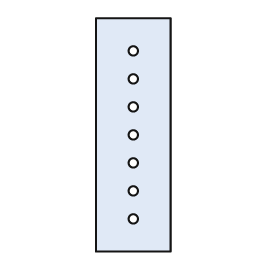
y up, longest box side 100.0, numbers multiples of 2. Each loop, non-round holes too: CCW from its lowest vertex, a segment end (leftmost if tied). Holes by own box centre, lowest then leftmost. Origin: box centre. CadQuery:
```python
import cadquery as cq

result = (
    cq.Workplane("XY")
    .moveTo(-16.0, -50.0)
    .lineTo(16.0, -50.0)
    .lineTo(16.0, 50.0)
    .lineTo(-16.0, 50.0)
    .close()
    .moveTo(0.0, -36.0)
    .circle(2.0)
    .moveTo(0.0, -24.0)
    .circle(2.0)
    .moveTo(0.0, -12.0)
    .circle(2.0)
    .moveTo(0.0, 0.0)
    .circle(2.0)
    .moveTo(0.0, 12.0)
    .circle(2.0)
    .moveTo(0.0, 24.0)
    .circle(2.0)
    .moveTo(0.0, 36.0)
    .circle(2.0)
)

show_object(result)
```